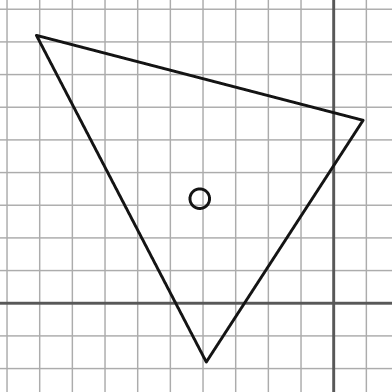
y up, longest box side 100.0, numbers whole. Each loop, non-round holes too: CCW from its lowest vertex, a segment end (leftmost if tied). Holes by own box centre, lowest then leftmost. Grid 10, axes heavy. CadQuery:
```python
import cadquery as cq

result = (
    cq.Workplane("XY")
    .moveTo(-39.0, -18.0)
    .lineTo(9.0, 56.0)
    .lineTo(-91.0, 82.0)
    .close()
    .moveTo(-41.0, 32.0)
    .circle(3.0)
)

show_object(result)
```